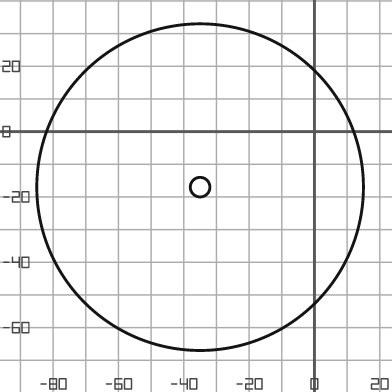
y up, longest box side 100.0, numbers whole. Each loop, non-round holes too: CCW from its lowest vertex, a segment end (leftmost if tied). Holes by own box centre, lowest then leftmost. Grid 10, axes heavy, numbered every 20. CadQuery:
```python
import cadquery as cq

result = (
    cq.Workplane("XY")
    .moveTo(-35.0, -17.0)
    .circle(50.0)
    .moveTo(-35.0, -17.0)
    .circle(3.0)
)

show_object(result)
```